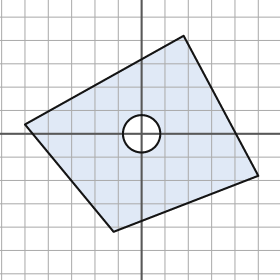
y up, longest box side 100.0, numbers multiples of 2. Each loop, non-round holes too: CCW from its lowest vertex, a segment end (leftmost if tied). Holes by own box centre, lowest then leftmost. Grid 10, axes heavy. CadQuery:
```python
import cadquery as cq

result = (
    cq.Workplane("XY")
    .moveTo(-12.0, -42.0)
    .lineTo(50.0, -18.0)
    .lineTo(18.0, 42.0)
    .lineTo(-50.0, 4.0)
    .close()
    .moveTo(0.0, 0.0)
    .circle(8.0)
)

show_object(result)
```